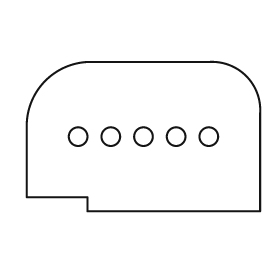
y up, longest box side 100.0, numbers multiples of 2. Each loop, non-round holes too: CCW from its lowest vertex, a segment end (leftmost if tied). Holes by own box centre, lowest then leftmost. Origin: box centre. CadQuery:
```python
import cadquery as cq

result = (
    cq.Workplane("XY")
    .moveTo(-24.0, -32.0)
    .lineTo(50.0, -32.0)
    .lineTo(50.0, 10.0)
    .threePointArc((44.0, 26.0), (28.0, 32.0))
    .lineTo(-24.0, 32.0)
    .threePointArc((-42.0, 24.0), (-50.0, 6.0))
    .lineTo(-50.0, -26.0)
    .lineTo(-24.0, -26.0)
    .close()
    .moveTo(-28.0, 0.0)
    .circle(4.0)
    .moveTo(-14.0, 0.0)
    .circle(4.0)
    .moveTo(0.0, 0.0)
    .circle(4.0)
    .moveTo(14.0, 0.0)
    .circle(4.0)
    .moveTo(28.0, 0.0)
    .circle(4.0)
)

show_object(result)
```